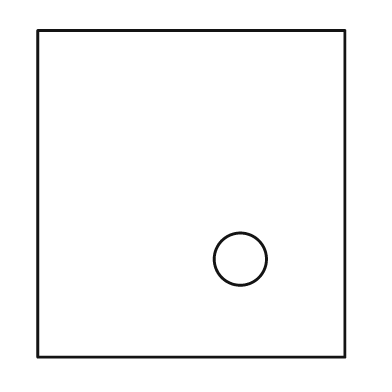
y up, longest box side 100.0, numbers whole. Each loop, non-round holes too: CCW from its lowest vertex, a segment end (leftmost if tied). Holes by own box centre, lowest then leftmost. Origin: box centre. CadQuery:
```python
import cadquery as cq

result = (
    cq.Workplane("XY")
    .moveTo(-47.0, -50.0)
    .lineTo(47.0, -50.0)
    .lineTo(47.0, 50.0)
    .lineTo(-47.0, 50.0)
    .close()
    .moveTo(15.0, -20.0)
    .circle(8.0)
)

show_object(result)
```